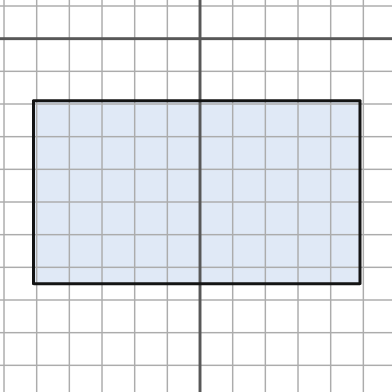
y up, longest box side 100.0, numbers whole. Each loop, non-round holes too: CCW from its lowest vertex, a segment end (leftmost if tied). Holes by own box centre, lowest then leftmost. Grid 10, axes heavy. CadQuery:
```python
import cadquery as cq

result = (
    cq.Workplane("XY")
    .moveTo(-51.0, -75.0)
    .lineTo(49.0, -75.0)
    .lineTo(49.0, -19.0)
    .lineTo(-51.0, -19.0)
    .close()
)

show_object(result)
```